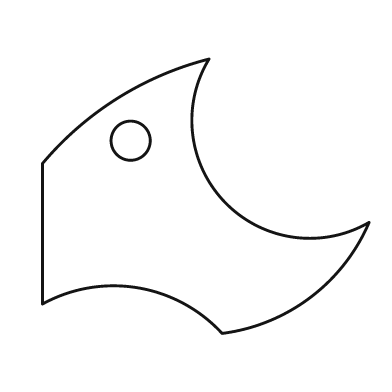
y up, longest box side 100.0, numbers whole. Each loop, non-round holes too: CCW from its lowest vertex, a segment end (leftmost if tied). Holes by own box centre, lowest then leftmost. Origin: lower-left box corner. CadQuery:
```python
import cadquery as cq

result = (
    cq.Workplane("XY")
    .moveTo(55.0, 0.0)
    .threePointArc((82.0, 11.0), (100.0, 34.0))
    .threePointArc((56.0, 40.0), (51.0, 84.0))
    .threePointArc((23.0, 72.0), (0.0, 52.0))
    .lineTo(0.0, 9.0)
    .threePointArc((29.0, 14.0), (55.0, 0.0))
    .close()
    .moveTo(27.0, 59.0)
    .circle(6.0)
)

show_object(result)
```